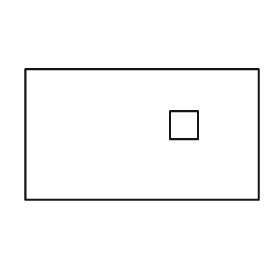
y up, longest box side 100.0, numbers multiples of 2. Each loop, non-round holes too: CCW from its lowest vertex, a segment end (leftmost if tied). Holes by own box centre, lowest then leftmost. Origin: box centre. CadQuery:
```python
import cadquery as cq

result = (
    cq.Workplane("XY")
    .moveTo(-50.0, -28.0)
    .lineTo(50.0, -28.0)
    .lineTo(50.0, 28.0)
    .lineTo(-50.0, 28.0)
    .close()
    .moveTo(12.0, -2.0)
    .lineTo(24.0, -2.0)
    .lineTo(24.0, 10.0)
    .lineTo(12.0, 10.0)
    .close()
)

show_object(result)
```